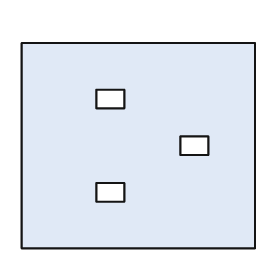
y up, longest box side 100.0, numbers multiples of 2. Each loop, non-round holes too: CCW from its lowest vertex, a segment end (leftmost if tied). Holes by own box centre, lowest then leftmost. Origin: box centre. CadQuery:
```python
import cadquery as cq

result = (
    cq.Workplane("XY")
    .moveTo(-50.0, -44.0)
    .lineTo(50.0, -44.0)
    .lineTo(50.0, 44.0)
    .lineTo(-50.0, 44.0)
    .close()
    .moveTo(-18.0, -24.0)
    .lineTo(-6.0, -24.0)
    .lineTo(-6.0, -16.0)
    .lineTo(-18.0, -16.0)
    .close()
    .moveTo(18.0, -4.0)
    .lineTo(30.0, -4.0)
    .lineTo(30.0, 4.0)
    .lineTo(18.0, 4.0)
    .close()
    .moveTo(-18.0, 16.0)
    .lineTo(-6.0, 16.0)
    .lineTo(-6.0, 24.0)
    .lineTo(-18.0, 24.0)
    .close()
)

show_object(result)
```